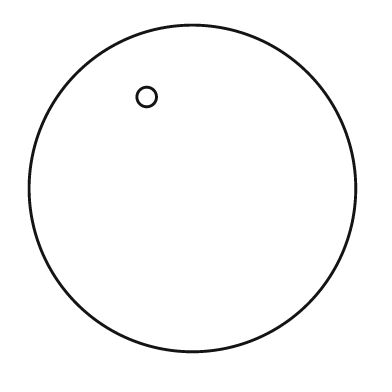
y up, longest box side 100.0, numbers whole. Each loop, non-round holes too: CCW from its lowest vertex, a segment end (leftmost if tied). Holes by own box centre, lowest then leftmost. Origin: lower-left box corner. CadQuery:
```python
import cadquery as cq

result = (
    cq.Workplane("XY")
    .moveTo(50.0, 50.0)
    .circle(50.0)
    .moveTo(36.0, 78.0)
    .circle(3.0)
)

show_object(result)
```